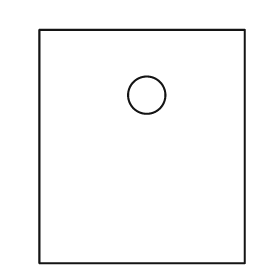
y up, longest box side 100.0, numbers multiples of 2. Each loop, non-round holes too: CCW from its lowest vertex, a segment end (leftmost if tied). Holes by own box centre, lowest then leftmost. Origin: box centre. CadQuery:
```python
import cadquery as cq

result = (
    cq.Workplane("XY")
    .moveTo(-44.0, -50.0)
    .lineTo(44.0, -50.0)
    .lineTo(44.0, 50.0)
    .lineTo(-44.0, 50.0)
    .close()
    .moveTo(2.0, 22.0)
    .circle(8.0)
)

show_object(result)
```